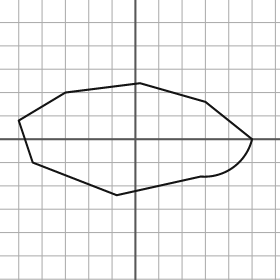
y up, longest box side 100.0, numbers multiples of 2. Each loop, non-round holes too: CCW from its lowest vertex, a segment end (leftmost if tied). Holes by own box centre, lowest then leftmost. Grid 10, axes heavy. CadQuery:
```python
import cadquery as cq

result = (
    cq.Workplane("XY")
    .moveTo(-8.0, -24.0)
    .lineTo(28.0, -16.0)
    .threePointArc((42.0, -12.0), (50.0, 0.0))
    .lineTo(30.0, 16.0)
    .lineTo(2.0, 24.0)
    .lineTo(-30.0, 20.0)
    .lineTo(-50.0, 8.0)
    .lineTo(-44.0, -10.0)
    .close()
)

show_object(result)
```